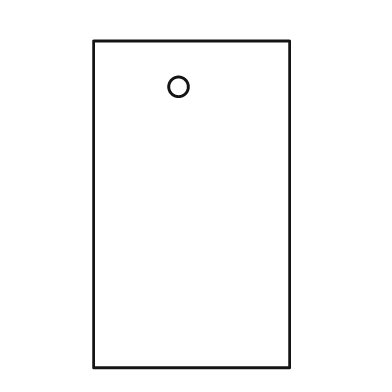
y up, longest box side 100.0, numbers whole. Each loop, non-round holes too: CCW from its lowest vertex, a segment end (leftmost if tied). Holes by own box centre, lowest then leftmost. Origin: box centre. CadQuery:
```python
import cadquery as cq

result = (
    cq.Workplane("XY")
    .moveTo(-30.0, -50.0)
    .lineTo(30.0, -50.0)
    .lineTo(30.0, 50.0)
    .lineTo(-30.0, 50.0)
    .close()
    .moveTo(-4.0, 36.0)
    .circle(3.0)
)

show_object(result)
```